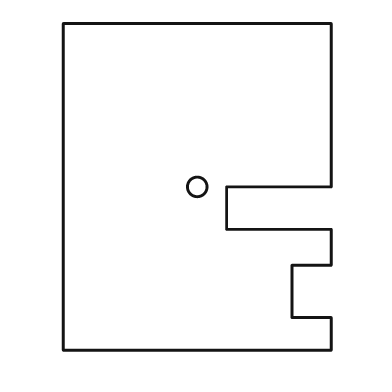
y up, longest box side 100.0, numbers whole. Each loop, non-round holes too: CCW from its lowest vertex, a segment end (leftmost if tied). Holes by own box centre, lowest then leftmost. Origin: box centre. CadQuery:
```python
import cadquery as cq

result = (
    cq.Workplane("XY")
    .moveTo(-41.0, -50.0)
    .lineTo(41.0, -50.0)
    .lineTo(41.0, -40.0)
    .lineTo(29.0, -40.0)
    .lineTo(29.0, -24.0)
    .lineTo(41.0, -24.0)
    .lineTo(41.0, -13.0)
    .lineTo(9.0, -13.0)
    .lineTo(9.0, 0.0)
    .lineTo(41.0, 0.0)
    .lineTo(41.0, 50.0)
    .lineTo(-41.0, 50.0)
    .close()
    .moveTo(0.0, 0.0)
    .circle(3.0)
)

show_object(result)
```